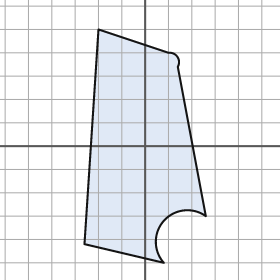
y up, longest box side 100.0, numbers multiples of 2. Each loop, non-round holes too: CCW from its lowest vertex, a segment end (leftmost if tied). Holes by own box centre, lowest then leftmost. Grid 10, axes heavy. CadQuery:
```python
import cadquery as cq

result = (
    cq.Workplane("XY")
    .moveTo(8.0, -50.0)
    .threePointArc((8.0, -32.0), (26.0, -30.0))
    .lineTo(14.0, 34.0)
    .threePointArc((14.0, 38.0), (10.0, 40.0))
    .lineTo(-20.0, 50.0)
    .lineTo(-26.0, -42.0)
    .close()
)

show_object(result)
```